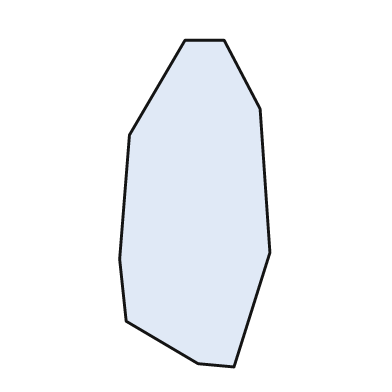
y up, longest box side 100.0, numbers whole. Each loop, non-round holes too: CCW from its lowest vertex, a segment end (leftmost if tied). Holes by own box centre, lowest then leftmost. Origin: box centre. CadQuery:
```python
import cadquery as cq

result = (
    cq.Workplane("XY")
    .moveTo(12.0, -50.0)
    .lineTo(23.0, -15.0)
    .lineTo(20.0, 29.0)
    .lineTo(9.0, 50.0)
    .lineTo(-3.0, 50.0)
    .lineTo(-20.0, 21.0)
    .lineTo(-23.0, -17.0)
    .lineTo(-21.0, -36.0)
    .lineTo(1.0, -49.0)
    .close()
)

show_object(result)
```